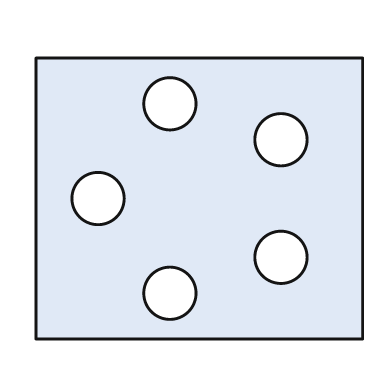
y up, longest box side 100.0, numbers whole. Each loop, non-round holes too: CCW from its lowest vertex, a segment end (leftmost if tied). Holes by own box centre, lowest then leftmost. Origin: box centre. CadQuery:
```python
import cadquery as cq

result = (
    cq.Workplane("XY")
    .moveTo(-50.0, -43.0)
    .lineTo(50.0, -43.0)
    .lineTo(50.0, 43.0)
    .lineTo(-50.0, 43.0)
    .close()
    .moveTo(-9.0, -29.0)
    .circle(8.0)
    .moveTo(25.0, -18.0)
    .circle(8.0)
    .moveTo(-31.0, 0.0)
    .circle(8.0)
    .moveTo(25.0, 18.0)
    .circle(8.0)
    .moveTo(-9.0, 29.0)
    .circle(8.0)
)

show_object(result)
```